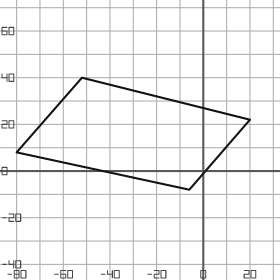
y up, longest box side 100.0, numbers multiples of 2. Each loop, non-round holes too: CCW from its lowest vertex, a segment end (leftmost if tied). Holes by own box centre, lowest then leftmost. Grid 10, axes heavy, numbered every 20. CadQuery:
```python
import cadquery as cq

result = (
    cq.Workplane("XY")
    .moveTo(-6.0, -8.0)
    .lineTo(20.0, 22.0)
    .lineTo(-52.0, 40.0)
    .lineTo(-80.0, 8.0)
    .close()
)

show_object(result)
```